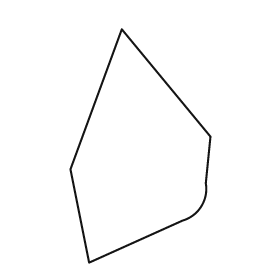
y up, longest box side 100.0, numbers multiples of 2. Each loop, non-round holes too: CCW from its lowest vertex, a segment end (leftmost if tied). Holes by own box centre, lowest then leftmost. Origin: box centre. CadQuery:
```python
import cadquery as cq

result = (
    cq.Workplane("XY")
    .moveTo(-22.0, -50.0)
    .lineTo(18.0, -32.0)
    .threePointArc((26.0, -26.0), (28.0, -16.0))
    .lineTo(30.0, 4.0)
    .lineTo(-8.0, 50.0)
    .lineTo(-30.0, -10.0)
    .close()
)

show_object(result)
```